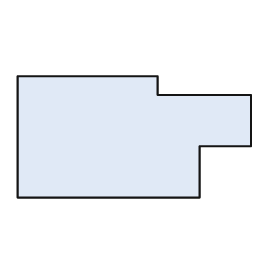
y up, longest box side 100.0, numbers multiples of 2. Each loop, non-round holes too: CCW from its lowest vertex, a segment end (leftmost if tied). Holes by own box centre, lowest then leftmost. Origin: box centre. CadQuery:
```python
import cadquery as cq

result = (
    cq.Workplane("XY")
    .moveTo(-50.0, -26.0)
    .lineTo(28.0, -26.0)
    .lineTo(28.0, -4.0)
    .lineTo(50.0, -4.0)
    .lineTo(50.0, 18.0)
    .lineTo(10.0, 18.0)
    .lineTo(10.0, 26.0)
    .lineTo(-50.0, 26.0)
    .close()
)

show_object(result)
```